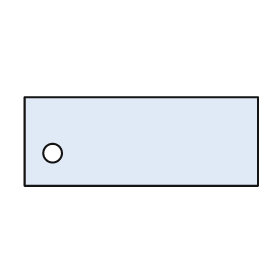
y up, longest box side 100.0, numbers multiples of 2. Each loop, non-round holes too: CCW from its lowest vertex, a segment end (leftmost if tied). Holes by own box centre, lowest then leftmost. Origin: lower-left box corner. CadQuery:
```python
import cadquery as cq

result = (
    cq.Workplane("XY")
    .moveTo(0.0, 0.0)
    .lineTo(100.0, 0.0)
    .lineTo(100.0, 38.0)
    .lineTo(0.0, 38.0)
    .close()
    .moveTo(12.0, 14.0)
    .circle(4.0)
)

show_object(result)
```